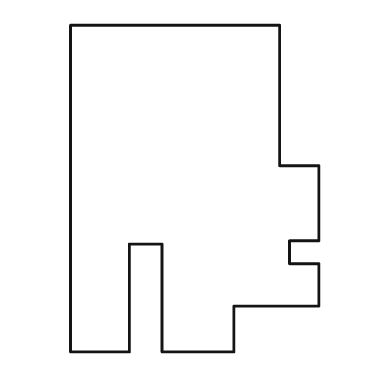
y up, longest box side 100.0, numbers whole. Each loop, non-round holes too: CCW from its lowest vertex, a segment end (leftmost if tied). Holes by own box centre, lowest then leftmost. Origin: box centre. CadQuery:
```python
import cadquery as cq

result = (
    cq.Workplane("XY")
    .moveTo(-38.0, -50.0)
    .lineTo(-20.0, -50.0)
    .lineTo(-20.0, -17.0)
    .lineTo(-10.0, -17.0)
    .lineTo(-10.0, -50.0)
    .lineTo(12.0, -50.0)
    .lineTo(12.0, -36.0)
    .lineTo(38.0, -36.0)
    .lineTo(38.0, -23.0)
    .lineTo(29.0, -23.0)
    .lineTo(29.0, -16.0)
    .lineTo(38.0, -16.0)
    .lineTo(38.0, 7.0)
    .lineTo(26.0, 7.0)
    .lineTo(26.0, 50.0)
    .lineTo(-38.0, 50.0)
    .close()
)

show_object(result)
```